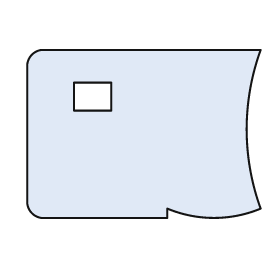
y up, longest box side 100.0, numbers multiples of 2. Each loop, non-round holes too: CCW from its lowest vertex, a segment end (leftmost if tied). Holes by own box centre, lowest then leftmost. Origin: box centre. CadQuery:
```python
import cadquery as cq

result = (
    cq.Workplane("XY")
    .moveTo(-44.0, -36.0)
    .lineTo(10.0, -36.0)
    .lineTo(10.0, -32.0)
    .threePointArc((30.0, -36.0), (50.0, -32.0))
    .threePointArc((44.0, 2.0), (50.0, 36.0))
    .lineTo(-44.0, 36.0)
    .threePointArc((-48.0, 34.0), (-50.0, 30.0))
    .lineTo(-50.0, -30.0)
    .threePointArc((-48.0, -34.0), (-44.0, -36.0))
    .close()
    .moveTo(-30.0, 10.0)
    .lineTo(-14.0, 10.0)
    .lineTo(-14.0, 22.0)
    .lineTo(-30.0, 22.0)
    .close()
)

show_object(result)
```